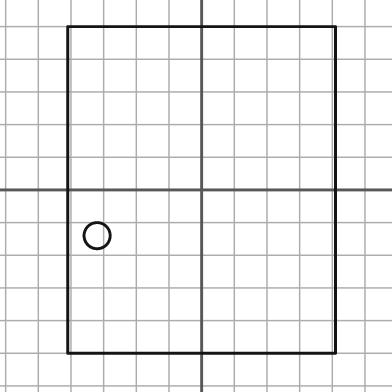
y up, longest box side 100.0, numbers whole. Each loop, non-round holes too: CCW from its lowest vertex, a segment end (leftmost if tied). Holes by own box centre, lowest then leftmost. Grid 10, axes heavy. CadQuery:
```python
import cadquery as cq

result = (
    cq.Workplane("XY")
    .moveTo(-41.0, -50.0)
    .lineTo(41.0, -50.0)
    .lineTo(41.0, 50.0)
    .lineTo(-41.0, 50.0)
    .close()
    .moveTo(-32.0, -14.0)
    .circle(4.0)
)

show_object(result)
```